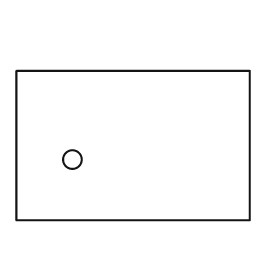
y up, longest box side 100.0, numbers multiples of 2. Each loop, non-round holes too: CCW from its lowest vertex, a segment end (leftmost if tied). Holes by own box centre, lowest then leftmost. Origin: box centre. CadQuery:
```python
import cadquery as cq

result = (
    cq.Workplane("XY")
    .moveTo(-50.0, -32.0)
    .lineTo(50.0, -32.0)
    .lineTo(50.0, 32.0)
    .lineTo(-50.0, 32.0)
    .close()
    .moveTo(-26.0, -6.0)
    .circle(4.0)
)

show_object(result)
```